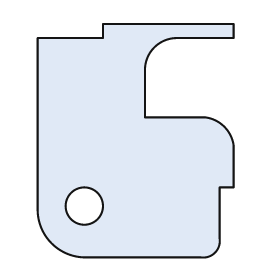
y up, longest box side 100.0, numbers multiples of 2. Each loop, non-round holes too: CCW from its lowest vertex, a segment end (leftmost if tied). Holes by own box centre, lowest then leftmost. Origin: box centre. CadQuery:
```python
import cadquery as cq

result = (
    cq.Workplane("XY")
    .moveTo(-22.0, -50.0)
    .lineTo(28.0, -50.0)
    .threePointArc((34.0, -48.0), (36.0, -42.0))
    .lineTo(36.0, -20.0)
    .lineTo(42.0, -20.0)
    .lineTo(42.0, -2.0)
    .threePointArc((38.0, 6.0), (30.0, 10.0))
    .lineTo(4.0, 10.0)
    .lineTo(4.0, 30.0)
    .threePointArc((8.0, 40.0), (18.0, 44.0))
    .lineTo(42.0, 44.0)
    .lineTo(42.0, 50.0)
    .lineTo(-14.0, 50.0)
    .lineTo(-14.0, 44.0)
    .lineTo(-42.0, 44.0)
    .lineTo(-42.0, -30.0)
    .threePointArc((-36.0, -44.0), (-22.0, -50.0))
    .close()
    .moveTo(-22.0, -28.0)
    .circle(8.0)
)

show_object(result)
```